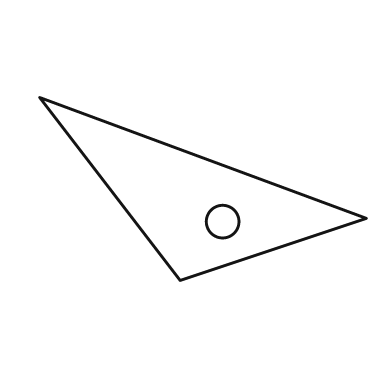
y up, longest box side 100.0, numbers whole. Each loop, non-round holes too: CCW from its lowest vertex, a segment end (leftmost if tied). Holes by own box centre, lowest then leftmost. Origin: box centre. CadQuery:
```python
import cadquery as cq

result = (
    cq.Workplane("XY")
    .moveTo(-7.0, -28.0)
    .lineTo(50.0, -9.0)
    .lineTo(-50.0, 28.0)
    .close()
    .moveTo(6.0, -10.0)
    .circle(5.0)
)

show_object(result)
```